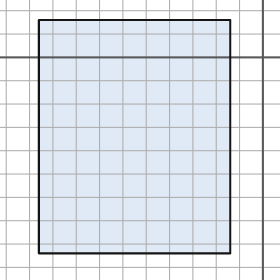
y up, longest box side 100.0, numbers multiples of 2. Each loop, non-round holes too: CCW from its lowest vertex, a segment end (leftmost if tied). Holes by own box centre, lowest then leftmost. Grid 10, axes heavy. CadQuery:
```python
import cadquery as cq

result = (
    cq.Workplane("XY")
    .moveTo(-96.0, -84.0)
    .lineTo(-14.0, -84.0)
    .lineTo(-14.0, 16.0)
    .lineTo(-96.0, 16.0)
    .close()
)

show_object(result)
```